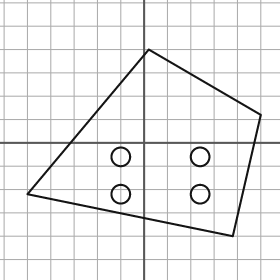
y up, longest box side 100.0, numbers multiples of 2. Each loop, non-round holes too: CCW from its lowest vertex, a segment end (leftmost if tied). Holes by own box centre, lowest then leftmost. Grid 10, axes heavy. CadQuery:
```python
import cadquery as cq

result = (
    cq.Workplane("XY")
    .moveTo(38.0, -40.0)
    .lineTo(50.0, 12.0)
    .lineTo(2.0, 40.0)
    .lineTo(-50.0, -22.0)
    .close()
    .moveTo(-10.0, -22.0)
    .circle(4.0)
    .moveTo(24.0, -22.0)
    .circle(4.0)
    .moveTo(-10.0, -6.0)
    .circle(4.0)
    .moveTo(24.0, -6.0)
    .circle(4.0)
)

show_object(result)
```